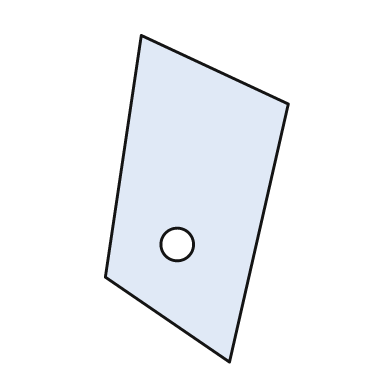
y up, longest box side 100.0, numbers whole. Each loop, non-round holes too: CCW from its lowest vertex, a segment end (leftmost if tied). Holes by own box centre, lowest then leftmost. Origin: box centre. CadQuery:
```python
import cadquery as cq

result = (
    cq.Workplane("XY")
    .moveTo(10.0, -50.0)
    .lineTo(28.0, 29.0)
    .lineTo(-17.0, 50.0)
    .lineTo(-28.0, -24.0)
    .close()
    .moveTo(-6.0, -14.0)
    .circle(5.0)
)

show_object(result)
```